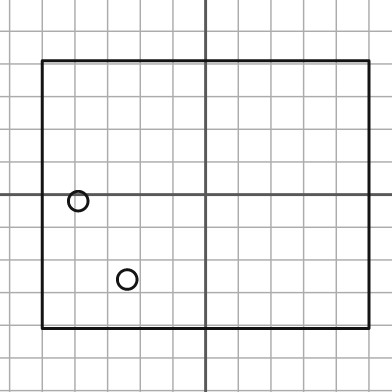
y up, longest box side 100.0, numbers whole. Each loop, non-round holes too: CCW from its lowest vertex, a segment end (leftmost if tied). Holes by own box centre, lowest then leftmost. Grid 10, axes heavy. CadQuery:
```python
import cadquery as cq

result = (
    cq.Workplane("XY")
    .moveTo(-50.0, -41.0)
    .lineTo(50.0, -41.0)
    .lineTo(50.0, 41.0)
    .lineTo(-50.0, 41.0)
    .close()
    .moveTo(-24.0, -26.0)
    .circle(3.0)
    .moveTo(-39.0, -2.0)
    .circle(3.0)
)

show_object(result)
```